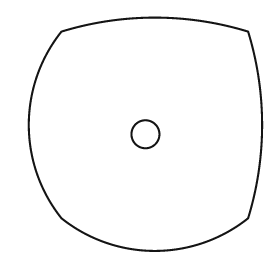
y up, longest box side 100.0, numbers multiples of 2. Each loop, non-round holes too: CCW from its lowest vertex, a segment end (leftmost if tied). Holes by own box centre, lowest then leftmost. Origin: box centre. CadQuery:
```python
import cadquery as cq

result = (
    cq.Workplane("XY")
    .moveTo(-36.0, -36.0)
    .threePointArc((4.0, -50.0), (44.0, -36.0))
    .threePointArc((50.0, 4.0), (44.0, 44.0))
    .threePointArc((4.0, 50.0), (-36.0, 44.0))
    .threePointArc((-50.0, 4.0), (-36.0, -36.0))
    .close()
    .moveTo(0.0, 0.0)
    .circle(6.0)
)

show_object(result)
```